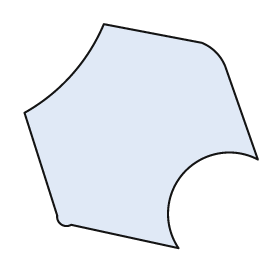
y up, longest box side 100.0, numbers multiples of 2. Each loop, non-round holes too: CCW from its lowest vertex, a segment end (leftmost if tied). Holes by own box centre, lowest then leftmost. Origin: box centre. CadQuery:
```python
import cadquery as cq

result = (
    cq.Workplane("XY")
    .moveTo(16.0, -48.0)
    .threePointArc((18.0, -16.0), (50.0, -10.0))
    .lineTo(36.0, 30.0)
    .threePointArc((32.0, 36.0), (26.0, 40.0))
    .lineTo(-16.0, 48.0)
    .threePointArc((-30.0, 26.0), (-50.0, 10.0))
    .lineTo(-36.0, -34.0)
    .threePointArc((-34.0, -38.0), (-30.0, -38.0))
    .close()
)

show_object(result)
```